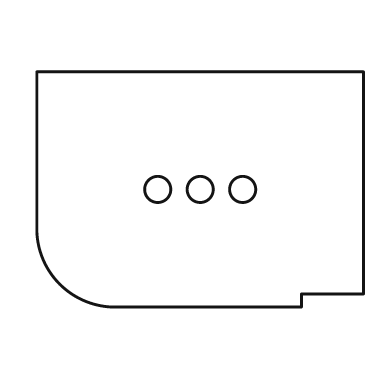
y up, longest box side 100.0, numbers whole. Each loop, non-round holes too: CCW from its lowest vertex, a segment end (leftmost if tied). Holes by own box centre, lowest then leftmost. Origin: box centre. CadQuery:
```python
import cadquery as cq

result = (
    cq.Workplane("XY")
    .moveTo(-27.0, -36.0)
    .lineTo(31.0, -36.0)
    .lineTo(31.0, -32.0)
    .lineTo(50.0, -32.0)
    .lineTo(50.0, 36.0)
    .lineTo(-50.0, 36.0)
    .lineTo(-50.0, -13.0)
    .threePointArc((-43.0, -29.0), (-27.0, -36.0))
    .close()
    .moveTo(-13.0, 0.0)
    .circle(4.0)
    .moveTo(0.0, 0.0)
    .circle(4.0)
    .moveTo(13.0, 0.0)
    .circle(4.0)
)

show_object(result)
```